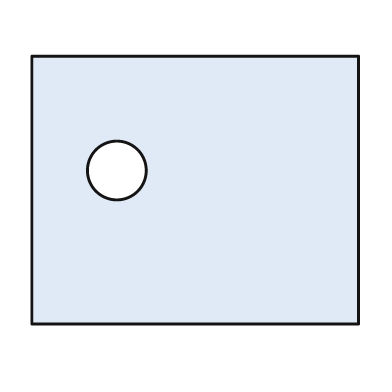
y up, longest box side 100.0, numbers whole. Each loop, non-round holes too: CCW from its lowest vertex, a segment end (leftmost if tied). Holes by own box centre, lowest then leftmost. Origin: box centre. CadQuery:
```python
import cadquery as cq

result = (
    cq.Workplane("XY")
    .moveTo(-50.0, -41.0)
    .lineTo(50.0, -41.0)
    .lineTo(50.0, 41.0)
    .lineTo(-50.0, 41.0)
    .close()
    .moveTo(-24.0, 6.0)
    .circle(9.0)
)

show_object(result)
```